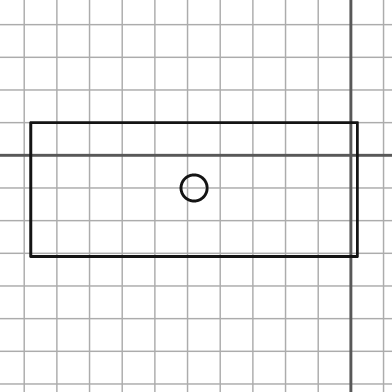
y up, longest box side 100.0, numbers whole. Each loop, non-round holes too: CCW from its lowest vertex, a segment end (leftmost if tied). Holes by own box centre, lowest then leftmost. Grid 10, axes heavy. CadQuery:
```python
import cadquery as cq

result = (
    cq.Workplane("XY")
    .moveTo(-98.0, -31.0)
    .lineTo(2.0, -31.0)
    .lineTo(2.0, 10.0)
    .lineTo(-98.0, 10.0)
    .close()
    .moveTo(-48.0, -10.0)
    .circle(4.0)
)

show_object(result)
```